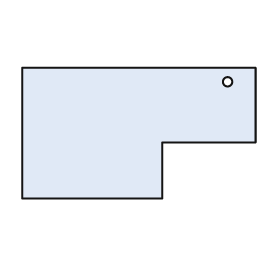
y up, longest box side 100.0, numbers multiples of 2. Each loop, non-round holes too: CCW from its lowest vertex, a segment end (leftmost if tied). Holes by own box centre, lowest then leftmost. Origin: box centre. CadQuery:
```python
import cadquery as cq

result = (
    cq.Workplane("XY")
    .moveTo(-50.0, -28.0)
    .lineTo(10.0, -28.0)
    .lineTo(10.0, -4.0)
    .lineTo(50.0, -4.0)
    .lineTo(50.0, 28.0)
    .lineTo(-50.0, 28.0)
    .close()
    .moveTo(38.0, 22.0)
    .circle(2.0)
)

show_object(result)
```